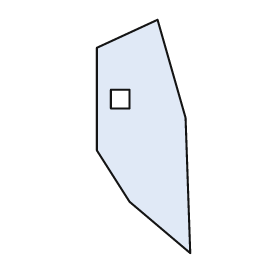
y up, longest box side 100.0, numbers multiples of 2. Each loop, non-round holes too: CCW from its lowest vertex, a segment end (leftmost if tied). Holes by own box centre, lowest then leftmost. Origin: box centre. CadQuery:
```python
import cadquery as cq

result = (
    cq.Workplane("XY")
    .moveTo(20.0, -50.0)
    .lineTo(18.0, 8.0)
    .lineTo(6.0, 50.0)
    .lineTo(-20.0, 38.0)
    .lineTo(-20.0, -6.0)
    .lineTo(-6.0, -28.0)
    .close()
    .moveTo(-14.0, 12.0)
    .lineTo(-6.0, 12.0)
    .lineTo(-6.0, 20.0)
    .lineTo(-14.0, 20.0)
    .close()
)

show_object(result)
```